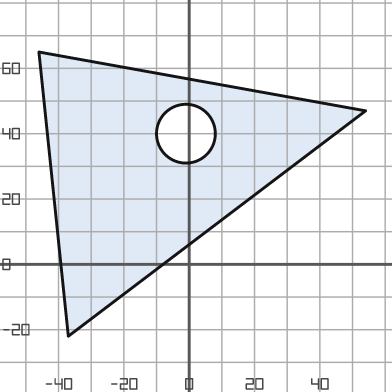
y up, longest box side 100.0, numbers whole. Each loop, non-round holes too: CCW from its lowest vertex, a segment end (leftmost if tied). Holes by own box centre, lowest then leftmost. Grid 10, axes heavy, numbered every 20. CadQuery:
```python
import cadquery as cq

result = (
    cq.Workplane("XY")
    .moveTo(-37.0, -22.0)
    .lineTo(54.0, 47.0)
    .lineTo(-46.0, 65.0)
    .close()
    .moveTo(-1.0, 40.0)
    .circle(9.0)
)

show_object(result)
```